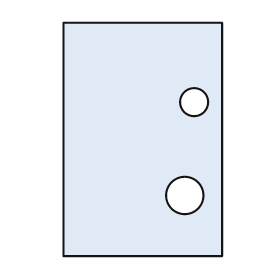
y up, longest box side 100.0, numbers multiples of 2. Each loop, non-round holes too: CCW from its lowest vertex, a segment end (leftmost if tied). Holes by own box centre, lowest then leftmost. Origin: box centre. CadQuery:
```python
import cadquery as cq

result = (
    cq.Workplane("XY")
    .moveTo(-34.0, -50.0)
    .lineTo(34.0, -50.0)
    .lineTo(34.0, 50.0)
    .lineTo(-34.0, 50.0)
    .close()
    .moveTo(18.0, -24.0)
    .circle(8.0)
    .moveTo(22.0, 16.0)
    .circle(6.0)
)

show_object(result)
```